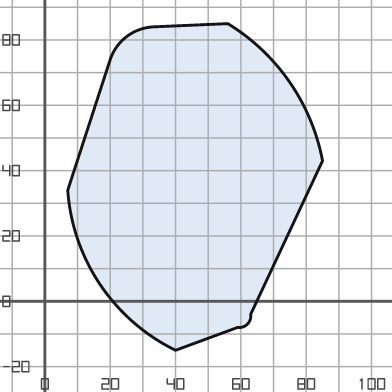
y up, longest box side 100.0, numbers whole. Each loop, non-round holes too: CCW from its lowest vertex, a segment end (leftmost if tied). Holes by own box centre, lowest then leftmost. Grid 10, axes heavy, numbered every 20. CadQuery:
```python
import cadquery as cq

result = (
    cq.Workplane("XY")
    .moveTo(40.0, -15.0)
    .lineTo(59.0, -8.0)
    .threePointArc((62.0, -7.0), (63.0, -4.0))
    .lineTo(85.0, 43.0)
    .threePointArc((75.0, 67.0), (56.0, 85.0))
    .lineTo(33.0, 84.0)
    .threePointArc((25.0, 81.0), (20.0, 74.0))
    .lineTo(7.0, 34.0)
    .threePointArc((17.0, 5.0), (40.0, -15.0))
    .close()
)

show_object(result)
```